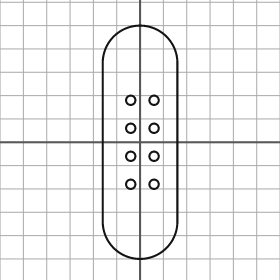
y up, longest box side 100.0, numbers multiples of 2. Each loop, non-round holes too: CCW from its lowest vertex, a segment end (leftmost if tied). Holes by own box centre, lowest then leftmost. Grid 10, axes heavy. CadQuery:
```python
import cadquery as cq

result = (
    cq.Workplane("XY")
    .moveTo(-16.0, -34.0)
    .threePointArc((0.0, -50.0), (16.0, -34.0))
    .lineTo(16.0, 34.0)
    .threePointArc((0.0, 50.0), (-16.0, 34.0))
    .close()
    .moveTo(-4.0, -18.0)
    .circle(2.0)
    .moveTo(6.0, -18.0)
    .circle(2.0)
    .moveTo(-4.0, -6.0)
    .circle(2.0)
    .moveTo(6.0, -6.0)
    .circle(2.0)
    .moveTo(-4.0, 6.0)
    .circle(2.0)
    .moveTo(6.0, 6.0)
    .circle(2.0)
    .moveTo(-4.0, 18.0)
    .circle(2.0)
    .moveTo(6.0, 18.0)
    .circle(2.0)
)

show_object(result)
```